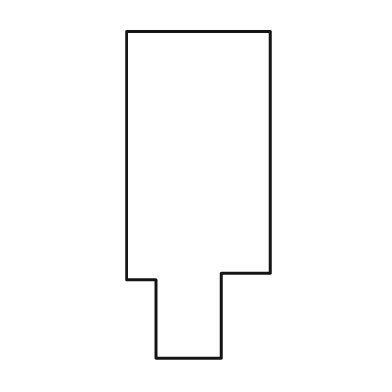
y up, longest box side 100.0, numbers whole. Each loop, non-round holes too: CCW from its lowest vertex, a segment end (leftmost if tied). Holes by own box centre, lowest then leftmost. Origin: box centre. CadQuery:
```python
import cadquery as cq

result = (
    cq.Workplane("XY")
    .moveTo(-13.0, -50.0)
    .lineTo(7.0, -50.0)
    .lineTo(7.0, -24.0)
    .lineTo(22.0, -24.0)
    .lineTo(22.0, 50.0)
    .lineTo(-22.0, 50.0)
    .lineTo(-22.0, -26.0)
    .lineTo(-13.0, -26.0)
    .close()
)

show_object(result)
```